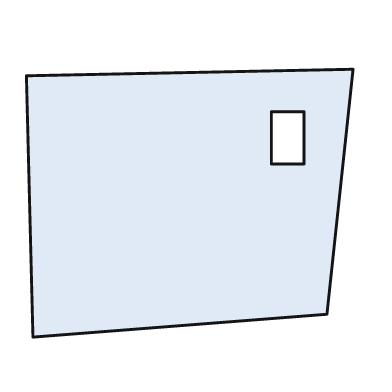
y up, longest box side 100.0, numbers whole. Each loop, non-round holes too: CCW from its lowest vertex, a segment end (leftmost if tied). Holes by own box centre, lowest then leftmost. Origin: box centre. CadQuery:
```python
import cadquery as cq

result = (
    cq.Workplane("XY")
    .moveTo(-48.0, -41.0)
    .lineTo(42.0, -34.0)
    .lineTo(50.0, 41.0)
    .lineTo(-50.0, 39.0)
    .close()
    .moveTo(25.0, 12.0)
    .lineTo(35.0, 12.0)
    .lineTo(35.0, 28.0)
    .lineTo(25.0, 28.0)
    .close()
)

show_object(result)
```